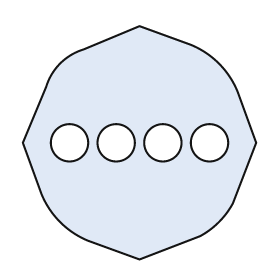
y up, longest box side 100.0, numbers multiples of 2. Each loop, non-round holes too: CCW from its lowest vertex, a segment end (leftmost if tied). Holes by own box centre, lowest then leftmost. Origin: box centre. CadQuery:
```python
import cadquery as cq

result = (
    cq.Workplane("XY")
    .moveTo(0.0, -50.0)
    .lineTo(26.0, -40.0)
    .threePointArc((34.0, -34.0), (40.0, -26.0))
    .lineTo(50.0, 0.0)
    .lineTo(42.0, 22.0)
    .threePointArc((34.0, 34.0), (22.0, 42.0))
    .lineTo(0.0, 50.0)
    .lineTo(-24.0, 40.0)
    .threePointArc((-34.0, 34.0), (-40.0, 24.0))
    .lineTo(-50.0, 0.0)
    .lineTo(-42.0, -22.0)
    .threePointArc((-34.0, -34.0), (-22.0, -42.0))
    .close()
    .moveTo(-30.0, 0.0)
    .circle(8.0)
    .moveTo(-10.0, 0.0)
    .circle(8.0)
    .moveTo(10.0, 0.0)
    .circle(8.0)
    .moveTo(30.0, 0.0)
    .circle(8.0)
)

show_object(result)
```